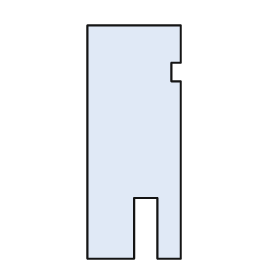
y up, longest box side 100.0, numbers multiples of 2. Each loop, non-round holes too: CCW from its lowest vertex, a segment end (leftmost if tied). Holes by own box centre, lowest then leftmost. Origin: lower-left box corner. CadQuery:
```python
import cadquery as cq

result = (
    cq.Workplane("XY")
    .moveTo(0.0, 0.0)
    .lineTo(20.0, 0.0)
    .lineTo(20.0, 26.0)
    .lineTo(30.0, 26.0)
    .lineTo(30.0, 0.0)
    .lineTo(40.0, 0.0)
    .lineTo(40.0, 76.0)
    .lineTo(36.0, 76.0)
    .lineTo(36.0, 84.0)
    .lineTo(40.0, 84.0)
    .lineTo(40.0, 100.0)
    .lineTo(0.0, 100.0)
    .close()
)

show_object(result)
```